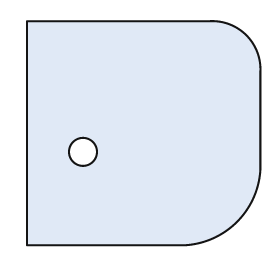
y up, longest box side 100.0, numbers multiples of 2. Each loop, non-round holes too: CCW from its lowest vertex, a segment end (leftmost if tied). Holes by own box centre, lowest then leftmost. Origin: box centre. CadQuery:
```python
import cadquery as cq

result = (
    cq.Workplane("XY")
    .moveTo(-50.0, -48.0)
    .lineTo(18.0, -48.0)
    .threePointArc((40.0, -38.0), (50.0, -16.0))
    .lineTo(50.0, 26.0)
    .threePointArc((44.0, 42.0), (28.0, 48.0))
    .lineTo(-50.0, 48.0)
    .close()
    .moveTo(-26.0, -8.0)
    .circle(6.0)
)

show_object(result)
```